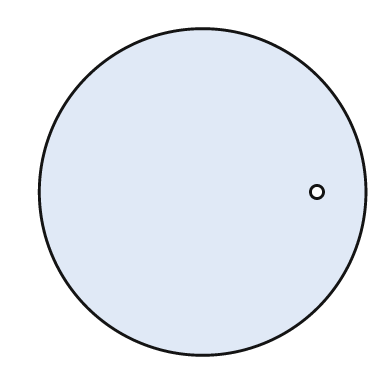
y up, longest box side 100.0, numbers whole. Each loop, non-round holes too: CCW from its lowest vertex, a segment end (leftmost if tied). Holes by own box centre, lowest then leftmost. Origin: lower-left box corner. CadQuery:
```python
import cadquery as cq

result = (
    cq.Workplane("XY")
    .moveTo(50.0, 50.0)
    .circle(50.0)
    .moveTo(85.0, 50.0)
    .circle(2.0)
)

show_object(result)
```